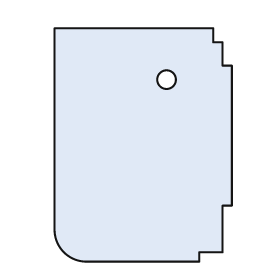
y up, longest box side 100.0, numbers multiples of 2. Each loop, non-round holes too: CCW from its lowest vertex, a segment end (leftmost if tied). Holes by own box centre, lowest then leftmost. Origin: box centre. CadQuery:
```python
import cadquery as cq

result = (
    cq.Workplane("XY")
    .moveTo(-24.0, -50.0)
    .lineTo(24.0, -50.0)
    .lineTo(24.0, -46.0)
    .lineTo(34.0, -46.0)
    .lineTo(34.0, -26.0)
    .lineTo(38.0, -26.0)
    .lineTo(38.0, 34.0)
    .lineTo(34.0, 34.0)
    .lineTo(34.0, 44.0)
    .lineTo(30.0, 44.0)
    .lineTo(30.0, 50.0)
    .lineTo(-38.0, 50.0)
    .lineTo(-38.0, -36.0)
    .threePointArc((-34.0, -46.0), (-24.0, -50.0))
    .close()
    .moveTo(10.0, 28.0)
    .circle(4.0)
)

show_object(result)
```